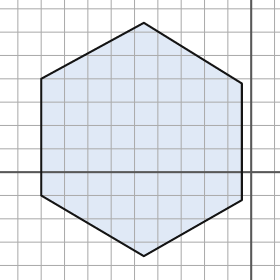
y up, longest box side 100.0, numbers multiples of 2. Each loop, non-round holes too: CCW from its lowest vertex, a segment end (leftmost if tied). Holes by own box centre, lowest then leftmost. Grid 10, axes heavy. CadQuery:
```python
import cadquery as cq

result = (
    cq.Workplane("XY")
    .moveTo(-46.0, -36.0)
    .lineTo(-4.0, -12.0)
    .lineTo(-4.0, 38.0)
    .lineTo(-46.0, 64.0)
    .lineTo(-90.0, 40.0)
    .lineTo(-90.0, -10.0)
    .close()
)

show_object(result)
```